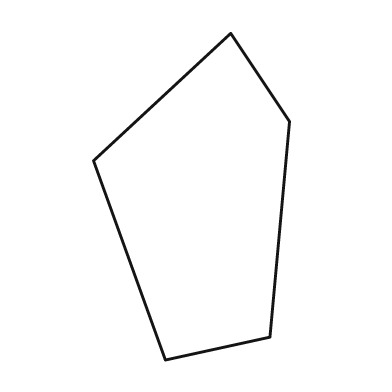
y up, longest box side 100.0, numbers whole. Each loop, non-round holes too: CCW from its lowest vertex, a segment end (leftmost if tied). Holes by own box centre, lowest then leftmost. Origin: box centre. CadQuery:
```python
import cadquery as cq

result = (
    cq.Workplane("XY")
    .moveTo(-8.0, -50.0)
    .lineTo(24.0, -43.0)
    .lineTo(30.0, 23.0)
    .lineTo(12.0, 50.0)
    .lineTo(-30.0, 11.0)
    .close()
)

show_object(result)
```